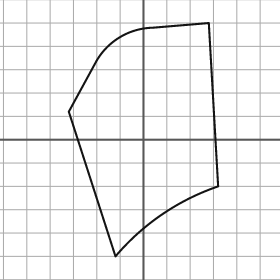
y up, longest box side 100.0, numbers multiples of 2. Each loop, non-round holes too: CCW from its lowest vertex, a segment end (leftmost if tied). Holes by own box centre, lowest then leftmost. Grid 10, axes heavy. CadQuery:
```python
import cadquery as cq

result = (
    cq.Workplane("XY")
    .moveTo(-12.0, -50.0)
    .threePointArc((8.0, -32.0), (32.0, -20.0))
    .lineTo(28.0, 50.0)
    .lineTo(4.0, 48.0)
    .threePointArc((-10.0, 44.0), (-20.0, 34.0))
    .lineTo(-32.0, 12.0)
    .close()
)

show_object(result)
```